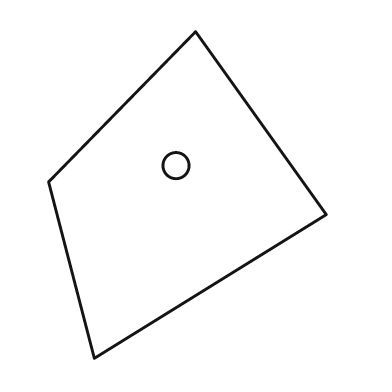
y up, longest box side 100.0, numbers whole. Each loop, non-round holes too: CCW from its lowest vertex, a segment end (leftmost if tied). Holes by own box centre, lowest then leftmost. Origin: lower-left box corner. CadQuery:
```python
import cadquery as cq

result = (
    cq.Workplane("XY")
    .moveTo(14.0, 0.0)
    .lineTo(85.0, 44.0)
    .lineTo(45.0, 100.0)
    .lineTo(0.0, 54.0)
    .close()
    .moveTo(39.0, 59.0)
    .circle(4.0)
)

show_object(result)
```